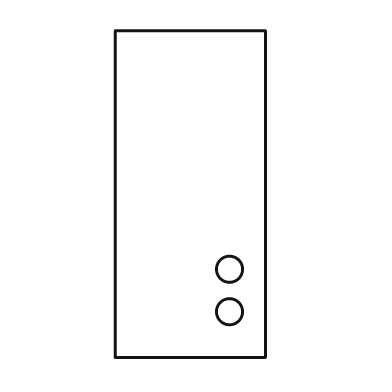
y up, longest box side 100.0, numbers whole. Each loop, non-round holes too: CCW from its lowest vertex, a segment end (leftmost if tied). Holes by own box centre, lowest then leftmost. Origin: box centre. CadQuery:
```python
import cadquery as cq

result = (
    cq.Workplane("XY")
    .moveTo(-23.0, -50.0)
    .lineTo(23.0, -50.0)
    .lineTo(23.0, 50.0)
    .lineTo(-23.0, 50.0)
    .close()
    .moveTo(12.0, -36.0)
    .circle(4.0)
    .moveTo(12.0, -23.0)
    .circle(4.0)
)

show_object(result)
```